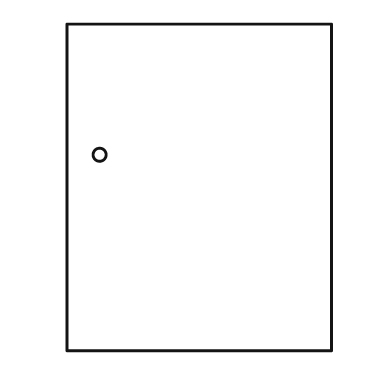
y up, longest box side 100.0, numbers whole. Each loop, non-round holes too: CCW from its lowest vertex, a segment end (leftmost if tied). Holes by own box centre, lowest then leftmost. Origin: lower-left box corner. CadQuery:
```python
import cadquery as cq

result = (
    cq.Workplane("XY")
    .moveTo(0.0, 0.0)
    .lineTo(81.0, 0.0)
    .lineTo(81.0, 100.0)
    .lineTo(0.0, 100.0)
    .close()
    .moveTo(10.0, 60.0)
    .circle(2.0)
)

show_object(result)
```